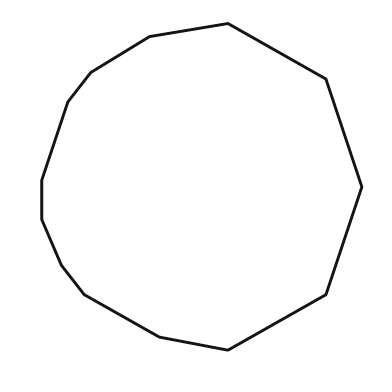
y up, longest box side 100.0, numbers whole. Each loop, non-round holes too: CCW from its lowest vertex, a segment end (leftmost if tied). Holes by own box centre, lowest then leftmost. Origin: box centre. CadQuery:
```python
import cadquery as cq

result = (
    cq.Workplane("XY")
    .moveTo(8.0, -50.0)
    .lineTo(38.0, -33.0)
    .lineTo(49.0, 0.0)
    .lineTo(38.0, 33.0)
    .lineTo(8.0, 50.0)
    .lineTo(-16.0, 46.0)
    .lineTo(-34.0, 35.0)
    .lineTo(-41.0, 26.0)
    .lineTo(-49.0, 2.0)
    .lineTo(-49.0, -10.0)
    .lineTo(-43.0, -24.0)
    .lineTo(-36.0, -33.0)
    .lineTo(-13.0, -46.0)
    .close()
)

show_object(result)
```